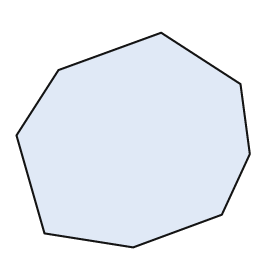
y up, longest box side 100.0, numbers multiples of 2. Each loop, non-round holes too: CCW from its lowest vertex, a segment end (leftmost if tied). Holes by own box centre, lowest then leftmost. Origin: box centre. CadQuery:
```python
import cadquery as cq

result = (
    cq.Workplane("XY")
    .moveTo(0.0, -46.0)
    .lineTo(38.0, -32.0)
    .lineTo(50.0, -6.0)
    .lineTo(46.0, 24.0)
    .lineTo(12.0, 46.0)
    .lineTo(-32.0, 30.0)
    .lineTo(-50.0, 2.0)
    .lineTo(-38.0, -40.0)
    .close()
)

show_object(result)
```